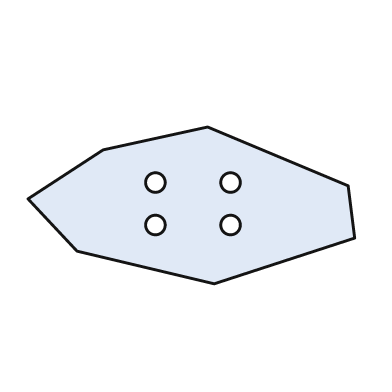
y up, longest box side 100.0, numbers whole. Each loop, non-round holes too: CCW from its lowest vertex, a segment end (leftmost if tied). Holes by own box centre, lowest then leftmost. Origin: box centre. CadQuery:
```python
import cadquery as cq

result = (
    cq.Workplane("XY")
    .moveTo(7.0, -24.0)
    .lineTo(50.0, -10.0)
    .lineTo(48.0, 6.0)
    .lineTo(5.0, 24.0)
    .lineTo(-27.0, 17.0)
    .lineTo(-50.0, 2.0)
    .lineTo(-35.0, -14.0)
    .close()
    .moveTo(-11.0, -6.0)
    .circle(3.0)
    .moveTo(12.0, -6.0)
    .circle(3.0)
    .moveTo(-11.0, 7.0)
    .circle(3.0)
    .moveTo(12.0, 7.0)
    .circle(3.0)
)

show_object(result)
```